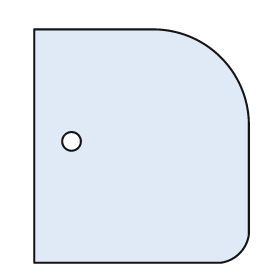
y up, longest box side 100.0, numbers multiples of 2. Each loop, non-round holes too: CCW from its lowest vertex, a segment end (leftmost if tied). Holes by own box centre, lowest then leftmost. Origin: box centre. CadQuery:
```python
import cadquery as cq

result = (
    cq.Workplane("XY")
    .moveTo(-46.0, -50.0)
    .lineTo(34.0, -50.0)
    .threePointArc((42.0, -46.0), (46.0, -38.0))
    .lineTo(46.0, 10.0)
    .threePointArc((34.0, 38.0), (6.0, 50.0))
    .lineTo(-46.0, 50.0)
    .close()
    .moveTo(-30.0, 2.0)
    .circle(4.0)
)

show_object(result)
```